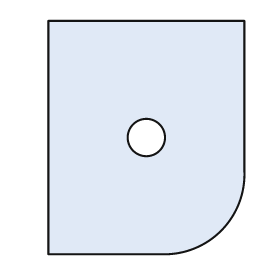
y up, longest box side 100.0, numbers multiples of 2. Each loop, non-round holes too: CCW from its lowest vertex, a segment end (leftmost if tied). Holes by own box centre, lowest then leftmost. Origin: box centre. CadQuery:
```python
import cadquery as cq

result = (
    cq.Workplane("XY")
    .moveTo(-42.0, -50.0)
    .lineTo(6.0, -50.0)
    .threePointArc((32.0, -40.0), (42.0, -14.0))
    .lineTo(42.0, 50.0)
    .lineTo(-42.0, 50.0)
    .close()
    .moveTo(0.0, 0.0)
    .circle(8.0)
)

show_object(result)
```